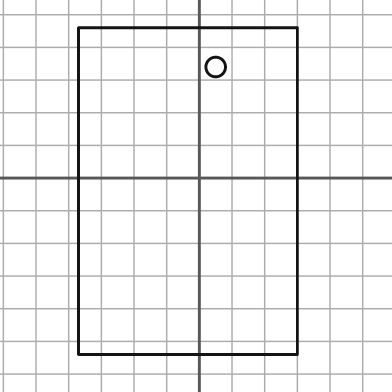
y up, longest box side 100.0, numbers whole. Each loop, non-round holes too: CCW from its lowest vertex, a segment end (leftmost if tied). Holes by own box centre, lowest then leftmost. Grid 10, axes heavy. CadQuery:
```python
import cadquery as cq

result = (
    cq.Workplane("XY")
    .moveTo(-37.0, -54.0)
    .lineTo(30.0, -54.0)
    .lineTo(30.0, 46.0)
    .lineTo(-37.0, 46.0)
    .close()
    .moveTo(5.0, 34.0)
    .circle(3.0)
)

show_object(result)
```